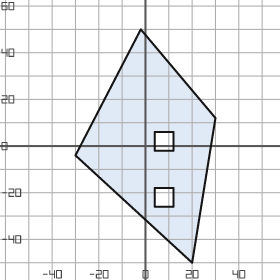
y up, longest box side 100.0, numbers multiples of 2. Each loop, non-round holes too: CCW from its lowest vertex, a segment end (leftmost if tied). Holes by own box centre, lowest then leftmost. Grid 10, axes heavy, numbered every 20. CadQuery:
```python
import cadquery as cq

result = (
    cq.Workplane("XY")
    .moveTo(20.0, -50.0)
    .lineTo(30.0, 12.0)
    .lineTo(-2.0, 50.0)
    .lineTo(-30.0, -4.0)
    .close()
    .moveTo(4.0, -26.0)
    .lineTo(12.0, -26.0)
    .lineTo(12.0, -18.0)
    .lineTo(4.0, -18.0)
    .close()
    .moveTo(4.0, -2.0)
    .lineTo(12.0, -2.0)
    .lineTo(12.0, 6.0)
    .lineTo(4.0, 6.0)
    .close()
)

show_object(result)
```